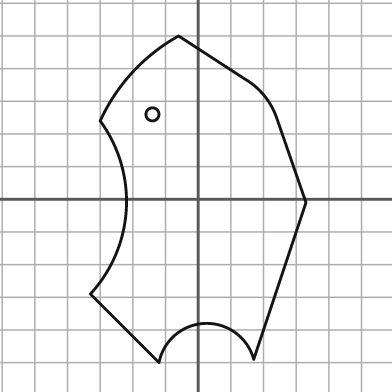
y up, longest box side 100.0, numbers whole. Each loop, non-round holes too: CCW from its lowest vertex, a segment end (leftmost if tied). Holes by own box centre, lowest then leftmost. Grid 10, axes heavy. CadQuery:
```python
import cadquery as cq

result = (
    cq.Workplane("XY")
    .moveTo(-12.0, -50.0)
    .threePointArc((2.0, -38.0), (17.0, -49.0))
    .lineTo(33.0, -1.0)
    .lineTo(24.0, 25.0)
    .threePointArc((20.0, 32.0), (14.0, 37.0))
    .lineTo(-6.0, 50.0)
    .threePointArc((-20.0, 39.0), (-30.0, 24.0))
    .threePointArc((-22.0, -3.0), (-33.0, -29.0))
    .close()
    .moveTo(-14.0, 26.0)
    .circle(2.0)
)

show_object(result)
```